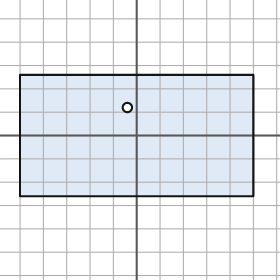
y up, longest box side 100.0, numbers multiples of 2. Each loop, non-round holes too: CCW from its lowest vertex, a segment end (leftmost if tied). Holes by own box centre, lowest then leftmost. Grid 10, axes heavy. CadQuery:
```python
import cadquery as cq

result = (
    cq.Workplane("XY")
    .moveTo(-50.0, -26.0)
    .lineTo(50.0, -26.0)
    .lineTo(50.0, 26.0)
    .lineTo(-50.0, 26.0)
    .close()
    .moveTo(-4.0, 12.0)
    .circle(2.0)
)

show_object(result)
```